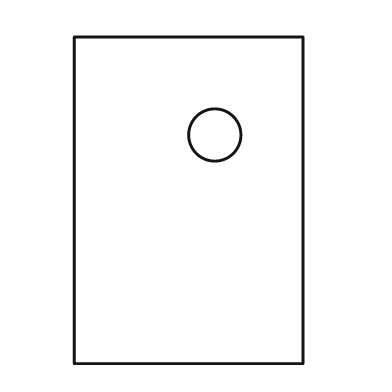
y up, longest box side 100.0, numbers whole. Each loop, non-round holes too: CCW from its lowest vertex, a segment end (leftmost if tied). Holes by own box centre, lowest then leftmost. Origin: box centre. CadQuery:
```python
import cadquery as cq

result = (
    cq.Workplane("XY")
    .moveTo(-35.0, -50.0)
    .lineTo(35.0, -50.0)
    .lineTo(35.0, 50.0)
    .lineTo(-35.0, 50.0)
    .close()
    .moveTo(8.0, 20.0)
    .circle(8.0)
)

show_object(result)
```